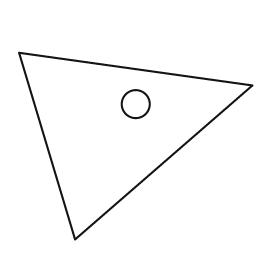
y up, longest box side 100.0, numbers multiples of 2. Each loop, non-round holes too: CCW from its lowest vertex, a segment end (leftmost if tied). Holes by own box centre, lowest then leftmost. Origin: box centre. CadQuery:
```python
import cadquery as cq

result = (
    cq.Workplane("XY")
    .moveTo(-26.0, -40.0)
    .lineTo(50.0, 26.0)
    .lineTo(-50.0, 40.0)
    .close()
    .moveTo(0.0, 18.0)
    .circle(6.0)
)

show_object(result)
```